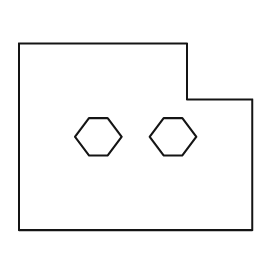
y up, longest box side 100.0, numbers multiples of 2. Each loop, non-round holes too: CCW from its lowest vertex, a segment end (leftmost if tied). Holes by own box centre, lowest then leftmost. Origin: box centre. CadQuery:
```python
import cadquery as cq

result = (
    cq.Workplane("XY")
    .moveTo(-50.0, -40.0)
    .lineTo(50.0, -40.0)
    .lineTo(50.0, 16.0)
    .lineTo(22.0, 16.0)
    .lineTo(22.0, 40.0)
    .lineTo(-50.0, 40.0)
    .close()
    .moveTo(-20.0, -8.0)
    .lineTo(-12.0, -8.0)
    .lineTo(-6.0, 0.0)
    .lineTo(-12.0, 8.0)
    .lineTo(-20.0, 8.0)
    .lineTo(-26.0, 0.0)
    .close()
    .moveTo(12.0, -8.0)
    .lineTo(20.0, -8.0)
    .lineTo(26.0, 0.0)
    .lineTo(20.0, 8.0)
    .lineTo(12.0, 8.0)
    .lineTo(6.0, 0.0)
    .close()
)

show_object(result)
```